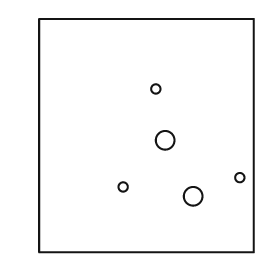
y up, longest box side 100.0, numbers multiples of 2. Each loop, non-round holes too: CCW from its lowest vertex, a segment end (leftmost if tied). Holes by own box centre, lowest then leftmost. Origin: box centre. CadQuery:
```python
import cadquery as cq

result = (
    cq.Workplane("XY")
    .moveTo(-46.0, -50.0)
    .lineTo(46.0, -50.0)
    .lineTo(46.0, 50.0)
    .lineTo(-46.0, 50.0)
    .close()
    .moveTo(20.0, -26.0)
    .circle(4.0)
    .moveTo(-10.0, -22.0)
    .circle(2.0)
    .moveTo(40.0, -18.0)
    .circle(2.0)
    .moveTo(8.0, -2.0)
    .circle(4.0)
    .moveTo(4.0, 20.0)
    .circle(2.0)
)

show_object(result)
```